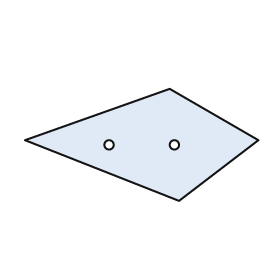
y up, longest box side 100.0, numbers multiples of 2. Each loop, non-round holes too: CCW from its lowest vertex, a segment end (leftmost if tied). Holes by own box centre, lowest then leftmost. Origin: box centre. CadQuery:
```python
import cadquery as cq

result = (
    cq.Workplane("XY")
    .moveTo(16.0, -24.0)
    .lineTo(50.0, 2.0)
    .lineTo(12.0, 24.0)
    .lineTo(-50.0, 2.0)
    .close()
    .moveTo(-14.0, 0.0)
    .circle(2.0)
    .moveTo(14.0, 0.0)
    .circle(2.0)
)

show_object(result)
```